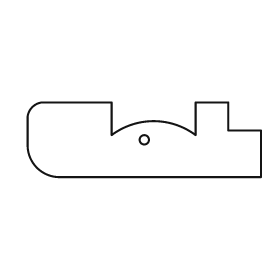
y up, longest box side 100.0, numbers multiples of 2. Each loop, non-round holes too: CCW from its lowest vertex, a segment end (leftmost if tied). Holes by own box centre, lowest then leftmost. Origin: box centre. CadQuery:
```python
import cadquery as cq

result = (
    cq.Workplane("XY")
    .moveTo(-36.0, -16.0)
    .lineTo(50.0, -16.0)
    .lineTo(50.0, 4.0)
    .lineTo(36.0, 4.0)
    .lineTo(36.0, 16.0)
    .lineTo(22.0, 16.0)
    .lineTo(22.0, 2.0)
    .threePointArc((4.0, 8.0), (-14.0, 2.0))
    .lineTo(-14.0, 16.0)
    .lineTo(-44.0, 16.0)
    .threePointArc((-48.0, 14.0), (-50.0, 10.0))
    .lineTo(-50.0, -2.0)
    .threePointArc((-46.0, -12.0), (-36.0, -16.0))
    .close()
    .moveTo(0.0, 0.0)
    .circle(2.0)
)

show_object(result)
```